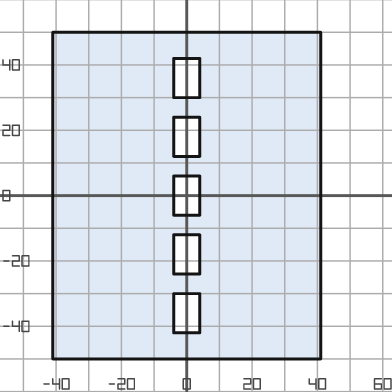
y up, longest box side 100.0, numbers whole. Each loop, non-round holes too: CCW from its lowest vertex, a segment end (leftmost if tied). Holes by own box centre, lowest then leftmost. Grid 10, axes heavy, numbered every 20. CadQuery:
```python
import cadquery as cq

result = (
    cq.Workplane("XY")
    .moveTo(-41.0, -50.0)
    .lineTo(41.0, -50.0)
    .lineTo(41.0, 50.0)
    .lineTo(-41.0, 50.0)
    .close()
    .moveTo(-4.0, -42.0)
    .lineTo(4.0, -42.0)
    .lineTo(4.0, -30.0)
    .lineTo(-4.0, -30.0)
    .close()
    .moveTo(-4.0, -24.0)
    .lineTo(4.0, -24.0)
    .lineTo(4.0, -12.0)
    .lineTo(-4.0, -12.0)
    .close()
    .moveTo(-4.0, -6.0)
    .lineTo(4.0, -6.0)
    .lineTo(4.0, 6.0)
    .lineTo(-4.0, 6.0)
    .close()
    .moveTo(-4.0, 12.0)
    .lineTo(4.0, 12.0)
    .lineTo(4.0, 24.0)
    .lineTo(-4.0, 24.0)
    .close()
    .moveTo(-4.0, 30.0)
    .lineTo(4.0, 30.0)
    .lineTo(4.0, 42.0)
    .lineTo(-4.0, 42.0)
    .close()
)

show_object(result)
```